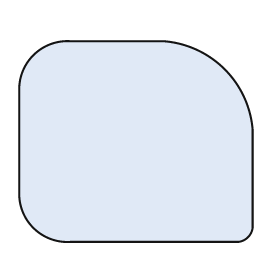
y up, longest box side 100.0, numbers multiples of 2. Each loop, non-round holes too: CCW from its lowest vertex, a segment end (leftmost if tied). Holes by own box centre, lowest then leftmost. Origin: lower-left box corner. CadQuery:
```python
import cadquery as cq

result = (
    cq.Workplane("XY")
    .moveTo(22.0, 0.0)
    .lineTo(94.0, 0.0)
    .threePointArc((98.0, 2.0), (100.0, 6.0))
    .lineTo(100.0, 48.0)
    .threePointArc((88.0, 74.0), (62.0, 86.0))
    .lineTo(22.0, 86.0)
    .threePointArc((6.0, 80.0), (0.0, 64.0))
    .lineTo(0.0, 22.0)
    .threePointArc((6.0, 6.0), (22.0, 0.0))
    .close()
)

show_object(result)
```